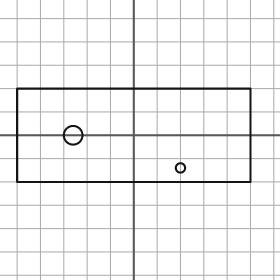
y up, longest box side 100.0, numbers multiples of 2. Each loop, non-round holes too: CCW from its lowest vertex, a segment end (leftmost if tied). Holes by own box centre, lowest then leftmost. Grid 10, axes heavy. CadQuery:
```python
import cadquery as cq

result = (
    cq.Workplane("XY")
    .moveTo(-50.0, -20.0)
    .lineTo(50.0, -20.0)
    .lineTo(50.0, 20.0)
    .lineTo(-50.0, 20.0)
    .close()
    .moveTo(20.0, -14.0)
    .circle(2.0)
    .moveTo(-26.0, 0.0)
    .circle(4.0)
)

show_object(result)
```